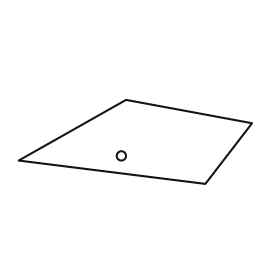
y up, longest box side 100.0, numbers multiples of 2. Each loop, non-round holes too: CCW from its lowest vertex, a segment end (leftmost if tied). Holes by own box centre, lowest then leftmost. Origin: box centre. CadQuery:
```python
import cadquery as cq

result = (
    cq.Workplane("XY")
    .moveTo(30.0, -18.0)
    .lineTo(50.0, 8.0)
    .lineTo(-4.0, 18.0)
    .lineTo(-50.0, -8.0)
    .close()
    .moveTo(-6.0, -6.0)
    .circle(2.0)
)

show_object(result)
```